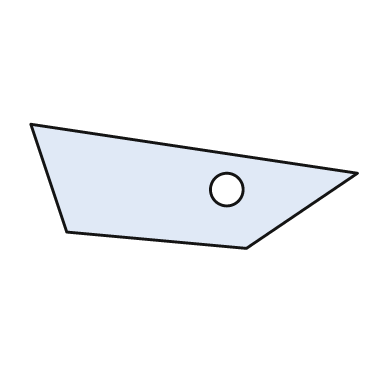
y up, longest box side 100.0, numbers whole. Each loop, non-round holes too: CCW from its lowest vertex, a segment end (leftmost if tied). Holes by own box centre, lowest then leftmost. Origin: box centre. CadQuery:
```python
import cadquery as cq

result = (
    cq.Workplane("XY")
    .moveTo(16.0, -19.0)
    .lineTo(50.0, 4.0)
    .lineTo(-50.0, 19.0)
    .lineTo(-39.0, -14.0)
    .close()
    .moveTo(10.0, -1.0)
    .circle(5.0)
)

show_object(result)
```